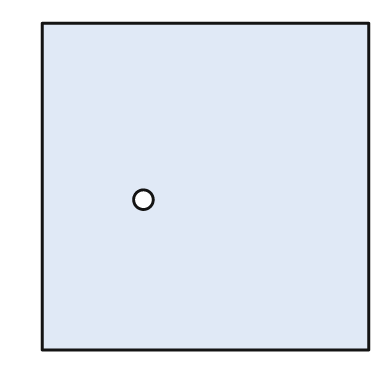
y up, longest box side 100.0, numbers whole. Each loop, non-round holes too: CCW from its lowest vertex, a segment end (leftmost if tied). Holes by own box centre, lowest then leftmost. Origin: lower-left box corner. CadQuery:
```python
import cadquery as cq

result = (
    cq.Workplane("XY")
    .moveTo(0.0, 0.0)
    .lineTo(100.0, 0.0)
    .lineTo(100.0, 100.0)
    .lineTo(0.0, 100.0)
    .close()
    .moveTo(31.0, 46.0)
    .circle(3.0)
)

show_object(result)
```